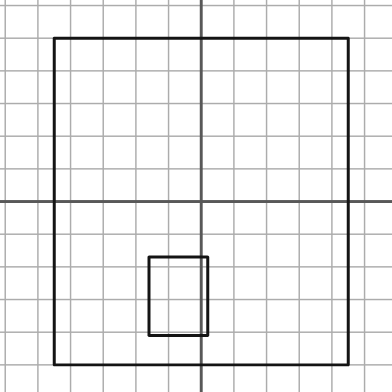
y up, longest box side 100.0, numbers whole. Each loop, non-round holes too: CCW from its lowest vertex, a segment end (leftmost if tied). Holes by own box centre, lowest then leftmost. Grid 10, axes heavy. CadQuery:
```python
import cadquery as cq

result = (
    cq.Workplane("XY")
    .moveTo(-45.0, -50.0)
    .lineTo(45.0, -50.0)
    .lineTo(45.0, 50.0)
    .lineTo(-45.0, 50.0)
    .close()
    .moveTo(-16.0, -41.0)
    .lineTo(2.0, -41.0)
    .lineTo(2.0, -17.0)
    .lineTo(-16.0, -17.0)
    .close()
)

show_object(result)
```